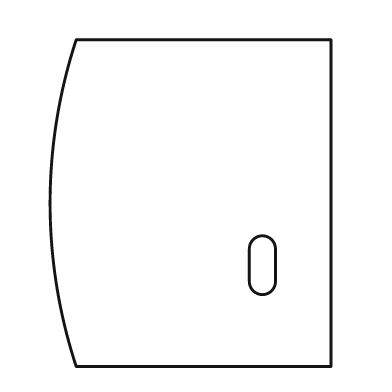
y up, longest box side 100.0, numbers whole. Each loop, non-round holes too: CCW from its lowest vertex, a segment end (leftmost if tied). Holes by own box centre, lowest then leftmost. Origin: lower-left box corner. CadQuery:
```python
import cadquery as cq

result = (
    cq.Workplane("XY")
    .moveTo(8.0, 0.0)
    .lineTo(86.0, 0.0)
    .lineTo(86.0, 100.0)
    .lineTo(8.0, 100.0)
    .threePointArc((0.0, 50.0), (8.0, 0.0))
    .close()
    .moveTo(61.0, 26.0)
    .threePointArc((65.0, 22.0), (69.0, 26.0))
    .lineTo(69.0, 36.0)
    .threePointArc((65.0, 40.0), (61.0, 36.0))
    .close()
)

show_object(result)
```